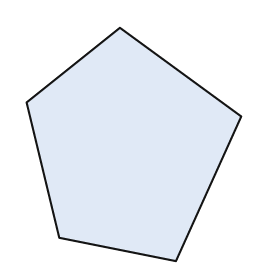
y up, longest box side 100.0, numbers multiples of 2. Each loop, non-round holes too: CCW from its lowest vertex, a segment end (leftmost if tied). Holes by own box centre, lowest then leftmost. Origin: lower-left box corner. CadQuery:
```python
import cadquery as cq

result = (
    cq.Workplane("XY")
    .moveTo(64.0, 0.0)
    .lineTo(92.0, 62.0)
    .lineTo(40.0, 100.0)
    .lineTo(0.0, 68.0)
    .lineTo(14.0, 10.0)
    .close()
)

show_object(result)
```